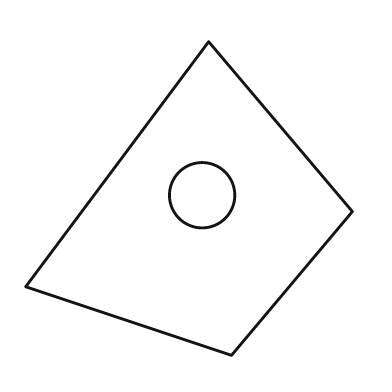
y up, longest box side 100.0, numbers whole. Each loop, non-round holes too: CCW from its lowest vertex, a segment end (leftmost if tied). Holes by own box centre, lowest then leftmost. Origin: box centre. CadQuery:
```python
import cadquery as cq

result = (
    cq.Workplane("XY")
    .moveTo(13.0, -48.0)
    .lineTo(50.0, -4.0)
    .lineTo(6.0, 48.0)
    .lineTo(-50.0, -27.0)
    .close()
    .moveTo(4.0, 1.0)
    .circle(10.0)
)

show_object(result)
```